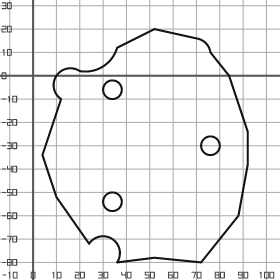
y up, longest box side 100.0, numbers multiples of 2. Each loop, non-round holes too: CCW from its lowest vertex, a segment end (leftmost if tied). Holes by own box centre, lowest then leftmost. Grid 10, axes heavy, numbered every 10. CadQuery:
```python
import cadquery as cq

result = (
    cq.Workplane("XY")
    .moveTo(36.0, -80.0)
    .lineTo(52.0, -78.0)
    .lineTo(72.0, -80.0)
    .lineTo(88.0, -60.0)
    .lineTo(92.0, -38.0)
    .lineTo(92.0, -24.0)
    .lineTo(84.0, 0.0)
    .lineTo(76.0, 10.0)
    .threePointArc((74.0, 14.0), (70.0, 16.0))
    .lineTo(52.0, 20.0)
    .lineTo(36.0, 12.0)
    .threePointArc((30.0, 4.0), (20.0, 2.0))
    .threePointArc((10.0, 0.0), (12.0, -10.0))
    .lineTo(4.0, -34.0)
    .lineTo(10.0, -52.0)
    .lineTo(24.0, -72.0)
    .threePointArc((34.0, -70.0), (36.0, -80.0))
    .close()
    .moveTo(34.0, -54.0)
    .circle(4.0)
    .moveTo(76.0, -30.0)
    .circle(4.0)
    .moveTo(34.0, -6.0)
    .circle(4.0)
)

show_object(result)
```